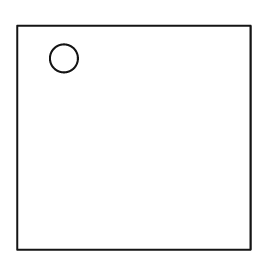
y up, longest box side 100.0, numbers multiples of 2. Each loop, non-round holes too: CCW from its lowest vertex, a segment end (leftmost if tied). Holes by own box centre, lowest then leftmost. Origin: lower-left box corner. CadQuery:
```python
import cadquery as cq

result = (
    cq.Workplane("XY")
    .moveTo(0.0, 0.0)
    .lineTo(100.0, 0.0)
    .lineTo(100.0, 96.0)
    .lineTo(0.0, 96.0)
    .close()
    .moveTo(20.0, 82.0)
    .circle(6.0)
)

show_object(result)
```